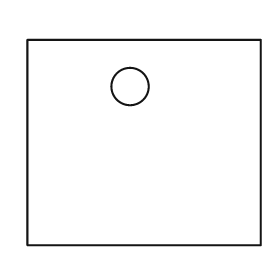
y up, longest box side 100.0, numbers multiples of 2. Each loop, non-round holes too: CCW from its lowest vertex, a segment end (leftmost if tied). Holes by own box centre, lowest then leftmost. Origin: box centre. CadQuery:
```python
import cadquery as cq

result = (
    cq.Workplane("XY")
    .moveTo(-50.0, -44.0)
    .lineTo(50.0, -44.0)
    .lineTo(50.0, 44.0)
    .lineTo(-50.0, 44.0)
    .close()
    .moveTo(-6.0, 24.0)
    .circle(8.0)
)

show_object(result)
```